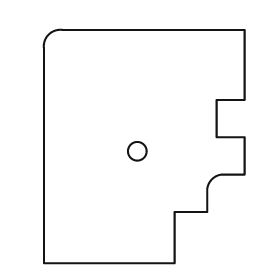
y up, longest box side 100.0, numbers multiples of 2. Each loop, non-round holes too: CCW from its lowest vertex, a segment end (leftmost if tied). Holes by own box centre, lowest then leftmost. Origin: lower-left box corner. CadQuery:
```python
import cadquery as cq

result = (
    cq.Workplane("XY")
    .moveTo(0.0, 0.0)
    .lineTo(56.0, 0.0)
    .lineTo(56.0, 22.0)
    .lineTo(70.0, 22.0)
    .lineTo(70.0, 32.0)
    .threePointArc((72.0, 36.0), (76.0, 38.0))
    .lineTo(86.0, 38.0)
    .lineTo(86.0, 54.0)
    .lineTo(74.0, 54.0)
    .lineTo(74.0, 70.0)
    .lineTo(86.0, 70.0)
    .lineTo(86.0, 100.0)
    .lineTo(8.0, 100.0)
    .threePointArc((2.0, 98.0), (0.0, 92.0))
    .close()
    .moveTo(40.0, 48.0)
    .circle(4.0)
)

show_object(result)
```